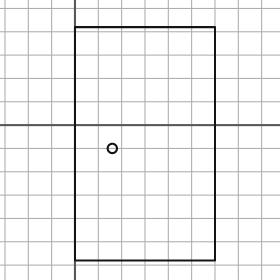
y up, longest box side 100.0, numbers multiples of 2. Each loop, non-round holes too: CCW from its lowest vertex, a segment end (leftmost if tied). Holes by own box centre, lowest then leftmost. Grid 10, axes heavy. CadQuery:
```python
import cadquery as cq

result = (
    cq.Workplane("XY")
    .moveTo(0.0, -58.0)
    .lineTo(60.0, -58.0)
    .lineTo(60.0, 42.0)
    .lineTo(0.0, 42.0)
    .close()
    .moveTo(16.0, -10.0)
    .circle(2.0)
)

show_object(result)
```